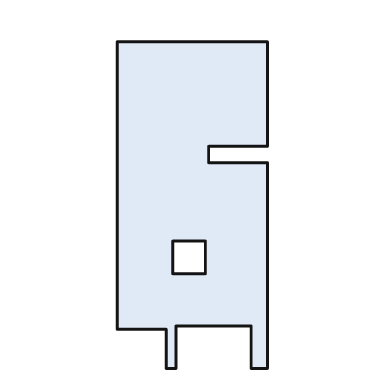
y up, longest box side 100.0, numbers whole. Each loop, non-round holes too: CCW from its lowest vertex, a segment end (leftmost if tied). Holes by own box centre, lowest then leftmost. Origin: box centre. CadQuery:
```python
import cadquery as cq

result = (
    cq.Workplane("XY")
    .moveTo(-8.0, -50.0)
    .lineTo(-5.0, -50.0)
    .lineTo(-5.0, -37.0)
    .lineTo(18.0, -37.0)
    .lineTo(18.0, -50.0)
    .lineTo(23.0, -50.0)
    .lineTo(23.0, 13.0)
    .lineTo(5.0, 13.0)
    .lineTo(5.0, 18.0)
    .lineTo(23.0, 18.0)
    .lineTo(23.0, 50.0)
    .lineTo(-23.0, 50.0)
    .lineTo(-23.0, -38.0)
    .lineTo(-8.0, -38.0)
    .close()
    .moveTo(-6.0, -21.0)
    .lineTo(4.0, -21.0)
    .lineTo(4.0, -11.0)
    .lineTo(-6.0, -11.0)
    .close()
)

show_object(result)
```